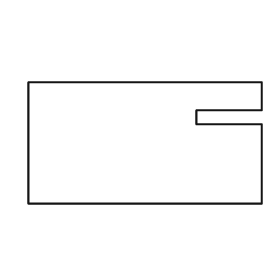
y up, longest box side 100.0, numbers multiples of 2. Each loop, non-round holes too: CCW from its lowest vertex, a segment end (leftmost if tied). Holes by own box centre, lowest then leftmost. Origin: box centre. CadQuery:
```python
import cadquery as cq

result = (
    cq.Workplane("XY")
    .moveTo(-50.0, -26.0)
    .lineTo(50.0, -26.0)
    .lineTo(50.0, 8.0)
    .lineTo(22.0, 8.0)
    .lineTo(22.0, 14.0)
    .lineTo(50.0, 14.0)
    .lineTo(50.0, 26.0)
    .lineTo(-50.0, 26.0)
    .close()
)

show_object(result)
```